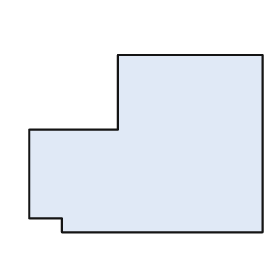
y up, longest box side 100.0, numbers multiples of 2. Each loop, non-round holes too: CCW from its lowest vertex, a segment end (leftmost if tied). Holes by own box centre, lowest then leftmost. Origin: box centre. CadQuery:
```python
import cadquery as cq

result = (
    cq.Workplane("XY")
    .moveTo(-36.0, -38.0)
    .lineTo(50.0, -38.0)
    .lineTo(50.0, 38.0)
    .lineTo(-12.0, 38.0)
    .lineTo(-12.0, 6.0)
    .lineTo(-50.0, 6.0)
    .lineTo(-50.0, -32.0)
    .lineTo(-36.0, -32.0)
    .close()
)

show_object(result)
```